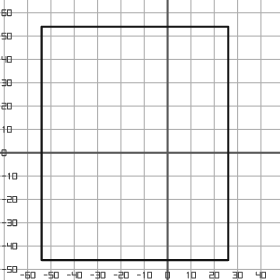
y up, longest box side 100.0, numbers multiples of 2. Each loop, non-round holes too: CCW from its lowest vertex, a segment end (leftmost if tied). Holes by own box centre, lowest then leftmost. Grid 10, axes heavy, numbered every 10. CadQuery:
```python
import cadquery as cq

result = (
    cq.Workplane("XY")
    .moveTo(-54.0, -46.0)
    .lineTo(26.0, -46.0)
    .lineTo(26.0, 54.0)
    .lineTo(-54.0, 54.0)
    .close()
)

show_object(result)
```